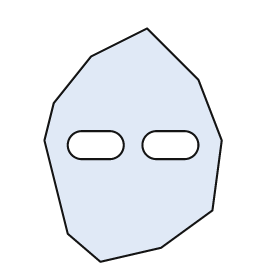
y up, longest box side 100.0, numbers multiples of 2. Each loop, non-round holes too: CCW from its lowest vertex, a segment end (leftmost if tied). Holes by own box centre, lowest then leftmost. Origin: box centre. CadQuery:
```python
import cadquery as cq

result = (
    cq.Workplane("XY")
    .moveTo(-14.0, -50.0)
    .lineTo(12.0, -44.0)
    .lineTo(34.0, -28.0)
    .lineTo(38.0, 2.0)
    .lineTo(28.0, 28.0)
    .lineTo(6.0, 50.0)
    .lineTo(-18.0, 38.0)
    .lineTo(-34.0, 18.0)
    .lineTo(-38.0, 2.0)
    .lineTo(-28.0, -38.0)
    .close()
    .moveTo(-22.0, -6.0)
    .lineTo(-10.0, -6.0)
    .threePointArc((-4.0, 0.0), (-10.0, 6.0))
    .lineTo(-22.0, 6.0)
    .threePointArc((-28.0, 0.0), (-22.0, -6.0))
    .close()
    .moveTo(10.0, -6.0)
    .lineTo(22.0, -6.0)
    .threePointArc((28.0, 0.0), (22.0, 6.0))
    .lineTo(10.0, 6.0)
    .threePointArc((4.0, 0.0), (10.0, -6.0))
    .close()
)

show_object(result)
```